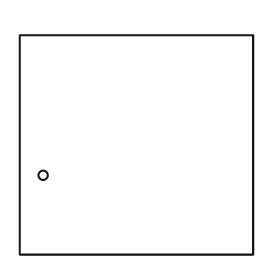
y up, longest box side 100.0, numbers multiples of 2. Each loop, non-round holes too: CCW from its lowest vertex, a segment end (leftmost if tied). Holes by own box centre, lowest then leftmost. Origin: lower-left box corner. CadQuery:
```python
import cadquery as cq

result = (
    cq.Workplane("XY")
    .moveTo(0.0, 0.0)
    .lineTo(100.0, 0.0)
    .lineTo(100.0, 94.0)
    .lineTo(0.0, 94.0)
    .close()
    .moveTo(10.0, 34.0)
    .circle(2.0)
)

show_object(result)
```